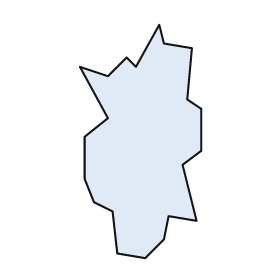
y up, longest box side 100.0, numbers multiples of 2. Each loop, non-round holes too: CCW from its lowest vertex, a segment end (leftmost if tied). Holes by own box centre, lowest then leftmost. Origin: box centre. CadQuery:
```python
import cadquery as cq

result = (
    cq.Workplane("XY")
    .moveTo(2.0, -50.0)
    .lineTo(10.0, -42.0)
    .lineTo(12.0, -32.0)
    .lineTo(24.0, -34.0)
    .lineTo(18.0, -10.0)
    .lineTo(26.0, -4.0)
    .lineTo(26.0, 14.0)
    .lineTo(20.0, 18.0)
    .lineTo(22.0, 40.0)
    .lineTo(10.0, 42.0)
    .lineTo(8.0, 50.0)
    .lineTo(-2.0, 32.0)
    .lineTo(-6.0, 36.0)
    .lineTo(-14.0, 28.0)
    .lineTo(-26.0, 32.0)
    .lineTo(-14.0, 10.0)
    .lineTo(-24.0, 2.0)
    .lineTo(-24.0, -16.0)
    .lineTo(-20.0, -26.0)
    .lineTo(-12.0, -30.0)
    .lineTo(-10.0, -48.0)
    .close()
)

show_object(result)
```